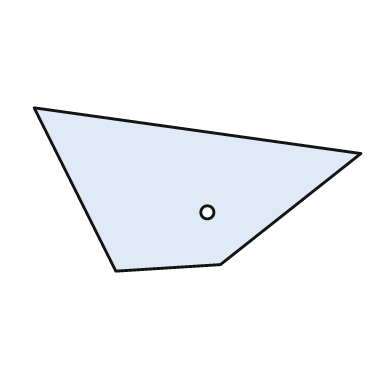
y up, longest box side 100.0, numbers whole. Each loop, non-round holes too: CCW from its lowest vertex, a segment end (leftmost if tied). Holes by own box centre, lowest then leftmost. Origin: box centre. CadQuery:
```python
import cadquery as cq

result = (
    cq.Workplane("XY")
    .moveTo(-25.0, -25.0)
    .lineTo(7.0, -23.0)
    .lineTo(50.0, 11.0)
    .lineTo(-50.0, 25.0)
    .close()
    .moveTo(3.0, -7.0)
    .circle(2.0)
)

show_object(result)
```